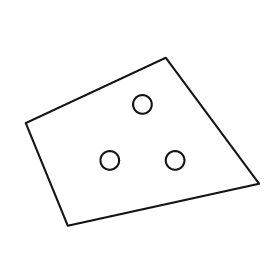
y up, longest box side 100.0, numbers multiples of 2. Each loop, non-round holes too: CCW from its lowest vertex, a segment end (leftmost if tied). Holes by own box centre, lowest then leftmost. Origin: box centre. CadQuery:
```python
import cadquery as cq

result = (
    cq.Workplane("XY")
    .moveTo(-32.0, -36.0)
    .lineTo(50.0, -18.0)
    .lineTo(10.0, 36.0)
    .lineTo(-50.0, 8.0)
    .close()
    .moveTo(-14.0, -8.0)
    .circle(4.0)
    .moveTo(14.0, -8.0)
    .circle(4.0)
    .moveTo(0.0, 16.0)
    .circle(4.0)
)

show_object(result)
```